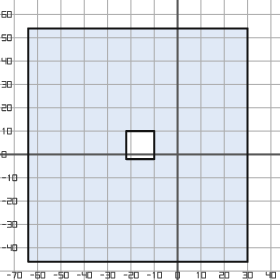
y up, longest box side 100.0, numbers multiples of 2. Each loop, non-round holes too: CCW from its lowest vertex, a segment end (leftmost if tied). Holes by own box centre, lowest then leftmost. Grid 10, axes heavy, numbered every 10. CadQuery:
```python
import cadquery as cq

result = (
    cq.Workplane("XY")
    .moveTo(-64.0, -46.0)
    .lineTo(30.0, -46.0)
    .lineTo(30.0, 54.0)
    .lineTo(-64.0, 54.0)
    .close()
    .moveTo(-22.0, -2.0)
    .lineTo(-10.0, -2.0)
    .lineTo(-10.0, 10.0)
    .lineTo(-22.0, 10.0)
    .close()
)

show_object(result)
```